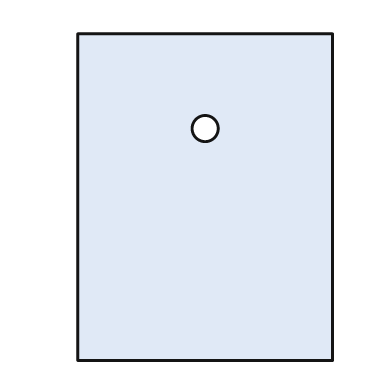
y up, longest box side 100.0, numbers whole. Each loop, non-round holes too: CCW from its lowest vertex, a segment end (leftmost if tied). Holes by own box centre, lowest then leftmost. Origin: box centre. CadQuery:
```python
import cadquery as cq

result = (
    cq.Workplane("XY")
    .moveTo(-39.0, -50.0)
    .lineTo(39.0, -50.0)
    .lineTo(39.0, 50.0)
    .lineTo(-39.0, 50.0)
    .close()
    .moveTo(0.0, 21.0)
    .circle(4.0)
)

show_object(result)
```